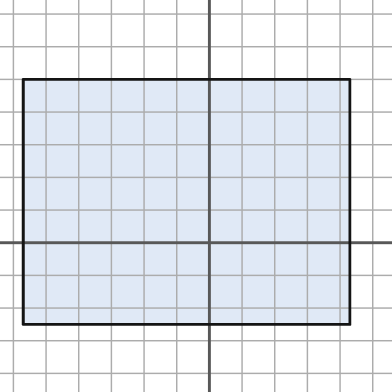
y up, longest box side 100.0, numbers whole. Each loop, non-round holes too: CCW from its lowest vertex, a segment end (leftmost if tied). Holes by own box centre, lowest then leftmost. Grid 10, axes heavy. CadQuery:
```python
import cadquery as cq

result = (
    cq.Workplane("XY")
    .moveTo(-57.0, -25.0)
    .lineTo(43.0, -25.0)
    .lineTo(43.0, 50.0)
    .lineTo(-57.0, 50.0)
    .close()
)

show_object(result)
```